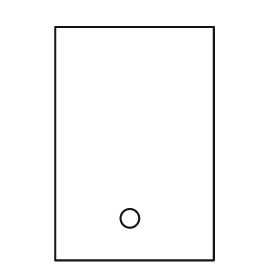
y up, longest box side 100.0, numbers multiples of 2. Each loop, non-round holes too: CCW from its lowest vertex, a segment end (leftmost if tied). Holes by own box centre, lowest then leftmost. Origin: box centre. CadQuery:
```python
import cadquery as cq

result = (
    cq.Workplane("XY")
    .moveTo(-34.0, -50.0)
    .lineTo(34.0, -50.0)
    .lineTo(34.0, 50.0)
    .lineTo(-34.0, 50.0)
    .close()
    .moveTo(-2.0, -32.0)
    .circle(4.0)
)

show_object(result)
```